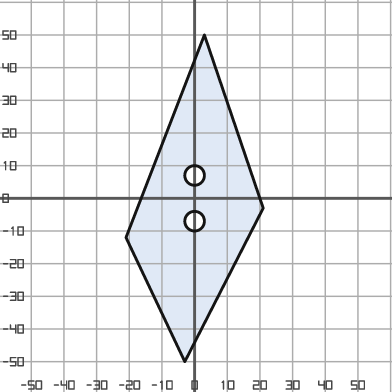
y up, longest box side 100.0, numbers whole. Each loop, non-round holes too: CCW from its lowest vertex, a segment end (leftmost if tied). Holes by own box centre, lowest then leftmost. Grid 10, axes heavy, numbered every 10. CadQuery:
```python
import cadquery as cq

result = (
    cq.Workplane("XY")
    .moveTo(-3.0, -50.0)
    .lineTo(21.0, -3.0)
    .lineTo(3.0, 50.0)
    .lineTo(-21.0, -12.0)
    .close()
    .moveTo(0.0, -7.0)
    .circle(3.0)
    .moveTo(0.0, 7.0)
    .circle(3.0)
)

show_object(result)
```